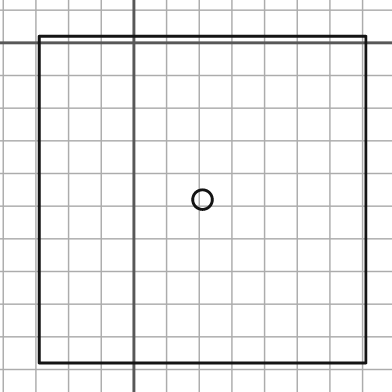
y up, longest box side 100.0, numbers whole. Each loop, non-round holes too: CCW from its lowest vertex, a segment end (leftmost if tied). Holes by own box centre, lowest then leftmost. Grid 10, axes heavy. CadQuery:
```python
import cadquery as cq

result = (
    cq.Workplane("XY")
    .moveTo(-29.0, -98.0)
    .lineTo(71.0, -98.0)
    .lineTo(71.0, 2.0)
    .lineTo(-29.0, 2.0)
    .close()
    .moveTo(21.0, -48.0)
    .circle(3.0)
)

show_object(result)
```